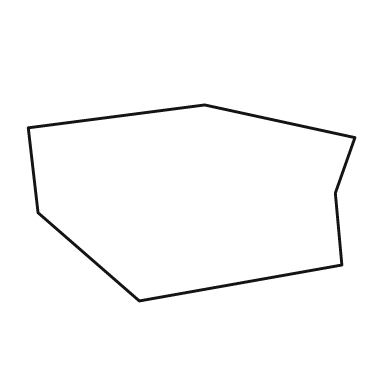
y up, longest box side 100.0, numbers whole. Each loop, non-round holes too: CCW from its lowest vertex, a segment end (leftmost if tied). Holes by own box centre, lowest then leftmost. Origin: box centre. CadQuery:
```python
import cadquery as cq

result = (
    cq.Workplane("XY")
    .moveTo(-16.0, -30.0)
    .lineTo(46.0, -19.0)
    .lineTo(44.0, 3.0)
    .lineTo(50.0, 20.0)
    .lineTo(4.0, 30.0)
    .lineTo(-50.0, 23.0)
    .lineTo(-47.0, -3.0)
    .close()
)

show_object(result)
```